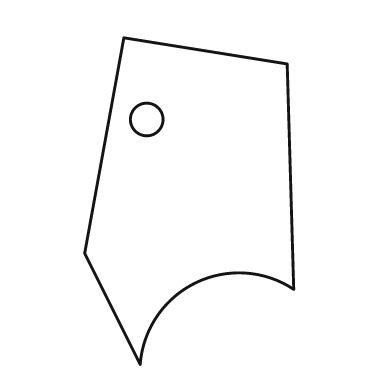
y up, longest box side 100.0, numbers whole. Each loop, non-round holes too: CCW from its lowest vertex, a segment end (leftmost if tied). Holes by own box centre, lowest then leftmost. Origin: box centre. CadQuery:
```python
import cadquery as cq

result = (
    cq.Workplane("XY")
    .moveTo(-15.0, -50.0)
    .threePointArc((2.0, -25.0), (32.0, -27.0))
    .lineTo(30.0, 42.0)
    .lineTo(-20.0, 50.0)
    .lineTo(-32.0, -16.0)
    .close()
    .moveTo(-13.0, 25.0)
    .circle(5.0)
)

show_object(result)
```